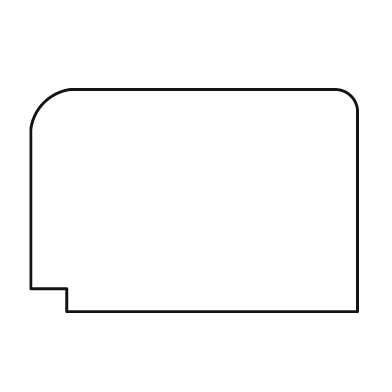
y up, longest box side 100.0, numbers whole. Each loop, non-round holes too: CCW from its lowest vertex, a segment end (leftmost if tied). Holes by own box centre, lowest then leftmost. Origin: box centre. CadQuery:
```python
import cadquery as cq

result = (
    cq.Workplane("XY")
    .moveTo(-39.0, -34.0)
    .lineTo(50.0, -34.0)
    .lineTo(50.0, 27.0)
    .threePointArc((48.0, 32.0), (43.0, 34.0))
    .lineTo(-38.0, 34.0)
    .threePointArc((-46.0, 30.0), (-50.0, 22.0))
    .lineTo(-50.0, -27.0)
    .lineTo(-39.0, -27.0)
    .close()
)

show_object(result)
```